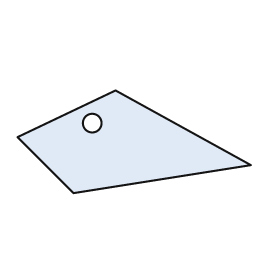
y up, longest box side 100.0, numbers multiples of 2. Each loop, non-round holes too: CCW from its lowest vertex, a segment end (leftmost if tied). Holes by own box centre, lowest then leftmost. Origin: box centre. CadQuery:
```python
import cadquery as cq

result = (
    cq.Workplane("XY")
    .moveTo(-26.0, -22.0)
    .lineTo(50.0, -10.0)
    .lineTo(-8.0, 22.0)
    .lineTo(-50.0, 2.0)
    .close()
    .moveTo(-18.0, 8.0)
    .circle(4.0)
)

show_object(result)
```